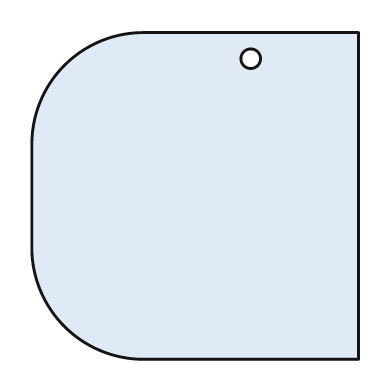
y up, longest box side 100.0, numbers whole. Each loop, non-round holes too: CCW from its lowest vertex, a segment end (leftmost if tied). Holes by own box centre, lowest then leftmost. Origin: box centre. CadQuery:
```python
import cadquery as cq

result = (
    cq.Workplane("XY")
    .moveTo(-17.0, -50.0)
    .lineTo(50.0, -50.0)
    .lineTo(50.0, 50.0)
    .lineTo(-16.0, 50.0)
    .threePointArc((-40.0, 40.0), (-50.0, 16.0))
    .lineTo(-50.0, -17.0)
    .threePointArc((-40.0, -40.0), (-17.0, -50.0))
    .close()
    .moveTo(17.0, 42.0)
    .circle(3.0)
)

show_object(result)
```